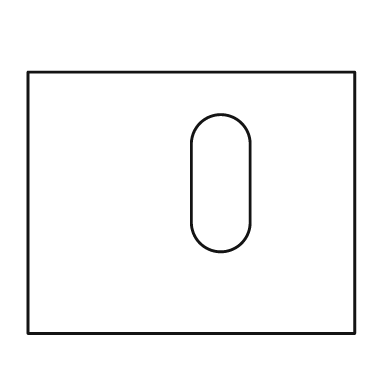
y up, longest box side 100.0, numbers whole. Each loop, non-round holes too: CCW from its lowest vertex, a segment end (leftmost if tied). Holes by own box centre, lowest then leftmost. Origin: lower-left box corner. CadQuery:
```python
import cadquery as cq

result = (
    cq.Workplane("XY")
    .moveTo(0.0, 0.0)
    .lineTo(100.0, 0.0)
    .lineTo(100.0, 80.0)
    .lineTo(0.0, 80.0)
    .close()
    .moveTo(50.0, 34.0)
    .threePointArc((59.0, 25.0), (68.0, 34.0))
    .lineTo(68.0, 58.0)
    .threePointArc((59.0, 67.0), (50.0, 58.0))
    .close()
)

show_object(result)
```